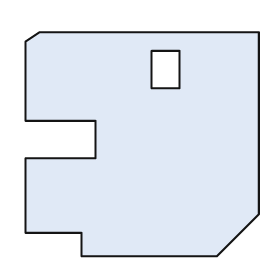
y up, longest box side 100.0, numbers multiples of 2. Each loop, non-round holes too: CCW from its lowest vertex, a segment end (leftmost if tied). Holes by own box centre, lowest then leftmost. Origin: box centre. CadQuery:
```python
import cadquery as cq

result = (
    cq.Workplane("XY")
    .moveTo(-26.0, -48.0)
    .lineTo(32.0, -48.0)
    .lineTo(50.0, -30.0)
    .lineTo(50.0, 48.0)
    .lineTo(-44.0, 48.0)
    .lineTo(-50.0, 44.0)
    .lineTo(-50.0, 10.0)
    .lineTo(-20.0, 10.0)
    .lineTo(-20.0, -6.0)
    .lineTo(-50.0, -6.0)
    .lineTo(-50.0, -38.0)
    .lineTo(-26.0, -38.0)
    .close()
    .moveTo(4.0, 24.0)
    .lineTo(16.0, 24.0)
    .lineTo(16.0, 40.0)
    .lineTo(4.0, 40.0)
    .close()
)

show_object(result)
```